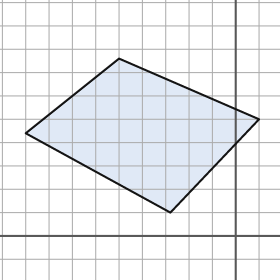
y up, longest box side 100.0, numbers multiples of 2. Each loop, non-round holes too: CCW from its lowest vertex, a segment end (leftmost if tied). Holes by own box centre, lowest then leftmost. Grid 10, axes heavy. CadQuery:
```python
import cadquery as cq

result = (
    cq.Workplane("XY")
    .moveTo(-28.0, 10.0)
    .lineTo(10.0, 50.0)
    .lineTo(-50.0, 76.0)
    .lineTo(-90.0, 44.0)
    .close()
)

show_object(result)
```